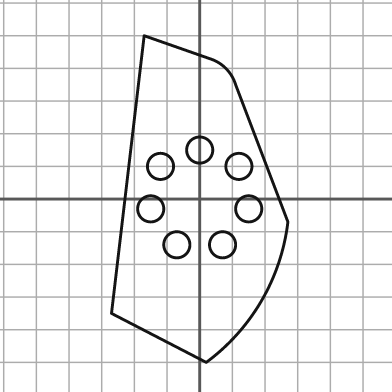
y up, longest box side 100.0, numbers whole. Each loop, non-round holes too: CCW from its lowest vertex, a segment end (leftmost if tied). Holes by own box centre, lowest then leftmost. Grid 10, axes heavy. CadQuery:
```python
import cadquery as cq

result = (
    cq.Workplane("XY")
    .moveTo(2.0, -50.0)
    .threePointArc((19.0, -31.0), (27.0, -7.0))
    .lineTo(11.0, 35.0)
    .threePointArc((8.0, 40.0), (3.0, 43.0))
    .lineTo(-17.0, 50.0)
    .lineTo(-27.0, -35.0)
    .close()
    .moveTo(-7.0, -14.0)
    .circle(4.0)
    .moveTo(7.0, -14.0)
    .circle(4.0)
    .moveTo(-15.0, -3.0)
    .circle(4.0)
    .moveTo(15.0, -3.0)
    .circle(4.0)
    .moveTo(-12.0, 10.0)
    .circle(4.0)
    .moveTo(12.0, 10.0)
    .circle(4.0)
    .moveTo(0.0, 15.0)
    .circle(4.0)
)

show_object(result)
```